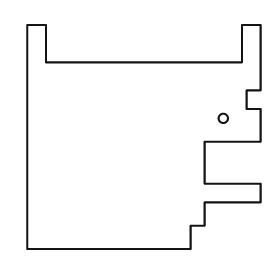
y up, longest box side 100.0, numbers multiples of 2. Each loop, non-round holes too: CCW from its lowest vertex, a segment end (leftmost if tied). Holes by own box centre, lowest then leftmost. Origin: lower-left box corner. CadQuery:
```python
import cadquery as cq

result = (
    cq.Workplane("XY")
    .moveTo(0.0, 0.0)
    .lineTo(70.0, 0.0)
    .lineTo(70.0, 10.0)
    .lineTo(76.0, 10.0)
    .lineTo(76.0, 20.0)
    .lineTo(100.0, 20.0)
    .lineTo(100.0, 28.0)
    .lineTo(76.0, 28.0)
    .lineTo(76.0, 46.0)
    .lineTo(100.0, 46.0)
    .lineTo(100.0, 60.0)
    .lineTo(94.0, 60.0)
    .lineTo(94.0, 68.0)
    .lineTo(100.0, 68.0)
    .lineTo(100.0, 96.0)
    .lineTo(92.0, 96.0)
    .lineTo(92.0, 80.0)
    .lineTo(8.0, 80.0)
    .lineTo(8.0, 96.0)
    .lineTo(0.0, 96.0)
    .close()
    .moveTo(84.0, 56.0)
    .circle(2.0)
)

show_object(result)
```